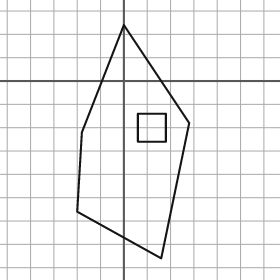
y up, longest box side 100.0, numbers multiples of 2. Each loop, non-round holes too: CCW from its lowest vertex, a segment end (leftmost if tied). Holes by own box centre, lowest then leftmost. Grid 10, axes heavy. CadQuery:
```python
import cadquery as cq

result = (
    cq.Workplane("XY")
    .moveTo(16.0, -76.0)
    .lineTo(28.0, -18.0)
    .lineTo(0.0, 24.0)
    .lineTo(-18.0, -22.0)
    .lineTo(-20.0, -56.0)
    .close()
    .moveTo(6.0, -26.0)
    .lineTo(18.0, -26.0)
    .lineTo(18.0, -14.0)
    .lineTo(6.0, -14.0)
    .close()
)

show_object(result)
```